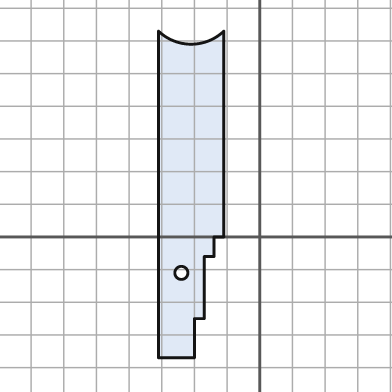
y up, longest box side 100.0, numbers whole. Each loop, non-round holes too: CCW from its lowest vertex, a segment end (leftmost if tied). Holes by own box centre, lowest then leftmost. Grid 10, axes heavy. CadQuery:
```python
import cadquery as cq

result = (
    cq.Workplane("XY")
    .moveTo(-31.0, -37.0)
    .lineTo(-20.0, -37.0)
    .lineTo(-20.0, -25.0)
    .lineTo(-17.0, -25.0)
    .lineTo(-17.0, -6.0)
    .lineTo(-14.0, -6.0)
    .lineTo(-14.0, 0.0)
    .lineTo(-11.0, 0.0)
    .lineTo(-11.0, 63.0)
    .threePointArc((-21.0, 59.0), (-31.0, 63.0))
    .close()
    .moveTo(-24.0, -11.0)
    .circle(2.0)
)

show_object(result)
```